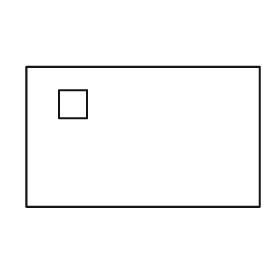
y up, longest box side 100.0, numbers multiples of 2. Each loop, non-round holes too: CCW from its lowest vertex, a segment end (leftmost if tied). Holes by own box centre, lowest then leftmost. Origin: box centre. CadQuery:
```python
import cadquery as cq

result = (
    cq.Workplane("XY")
    .moveTo(-50.0, -30.0)
    .lineTo(50.0, -30.0)
    .lineTo(50.0, 30.0)
    .lineTo(-50.0, 30.0)
    .close()
    .moveTo(-36.0, 8.0)
    .lineTo(-24.0, 8.0)
    .lineTo(-24.0, 20.0)
    .lineTo(-36.0, 20.0)
    .close()
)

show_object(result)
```